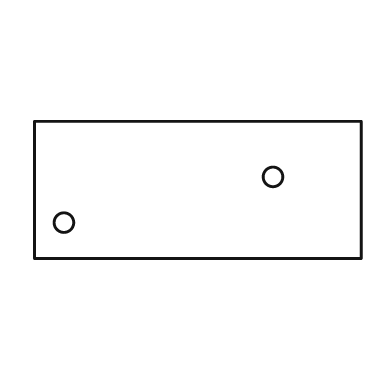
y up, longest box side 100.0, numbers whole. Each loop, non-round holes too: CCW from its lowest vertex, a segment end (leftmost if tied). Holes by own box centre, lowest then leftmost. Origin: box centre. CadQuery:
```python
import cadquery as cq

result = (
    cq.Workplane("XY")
    .moveTo(-50.0, -21.0)
    .lineTo(50.0, -21.0)
    .lineTo(50.0, 21.0)
    .lineTo(-50.0, 21.0)
    .close()
    .moveTo(-41.0, -10.0)
    .circle(3.0)
    .moveTo(23.0, 4.0)
    .circle(3.0)
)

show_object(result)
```